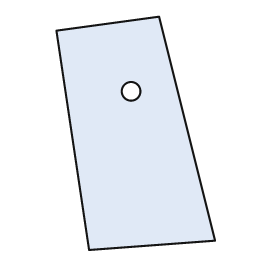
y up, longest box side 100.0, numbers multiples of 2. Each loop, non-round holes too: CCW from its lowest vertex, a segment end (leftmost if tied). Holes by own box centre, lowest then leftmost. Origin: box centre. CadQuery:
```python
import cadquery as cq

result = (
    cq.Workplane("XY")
    .moveTo(-20.0, -50.0)
    .lineTo(34.0, -46.0)
    .lineTo(10.0, 50.0)
    .lineTo(-34.0, 44.0)
    .close()
    .moveTo(-2.0, 18.0)
    .circle(4.0)
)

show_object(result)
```